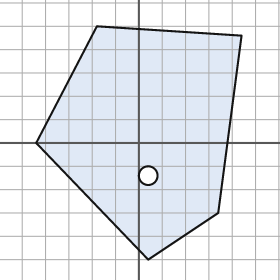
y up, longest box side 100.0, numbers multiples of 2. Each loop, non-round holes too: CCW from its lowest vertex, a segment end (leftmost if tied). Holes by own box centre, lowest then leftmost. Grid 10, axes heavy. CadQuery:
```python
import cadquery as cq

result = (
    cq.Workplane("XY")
    .moveTo(4.0, -50.0)
    .lineTo(34.0, -30.0)
    .lineTo(44.0, 46.0)
    .lineTo(-18.0, 50.0)
    .lineTo(-44.0, 0.0)
    .close()
    .moveTo(4.0, -14.0)
    .circle(4.0)
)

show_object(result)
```